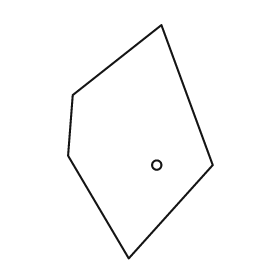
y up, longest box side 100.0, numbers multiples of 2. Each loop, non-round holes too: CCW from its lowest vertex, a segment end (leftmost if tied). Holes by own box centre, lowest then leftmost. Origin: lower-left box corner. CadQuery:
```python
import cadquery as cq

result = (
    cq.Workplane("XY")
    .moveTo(26.0, 0.0)
    .lineTo(62.0, 40.0)
    .lineTo(40.0, 100.0)
    .lineTo(2.0, 70.0)
    .lineTo(0.0, 44.0)
    .close()
    .moveTo(38.0, 40.0)
    .circle(2.0)
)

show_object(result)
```